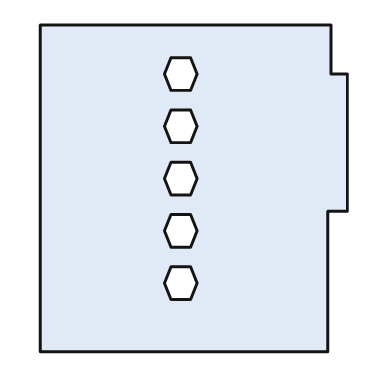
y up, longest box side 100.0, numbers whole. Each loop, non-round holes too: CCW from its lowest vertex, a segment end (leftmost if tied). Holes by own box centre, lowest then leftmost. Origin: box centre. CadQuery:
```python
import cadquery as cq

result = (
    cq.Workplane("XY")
    .moveTo(-47.0, -50.0)
    .lineTo(41.0, -50.0)
    .lineTo(41.0, -7.0)
    .lineTo(47.0, -7.0)
    .lineTo(47.0, 35.0)
    .lineTo(42.0, 35.0)
    .lineTo(42.0, 50.0)
    .lineTo(-47.0, 50.0)
    .close()
    .moveTo(-7.0, -34.0)
    .lineTo(-1.0, -34.0)
    .lineTo(1.0, -29.0)
    .lineTo(-1.0, -24.0)
    .lineTo(-7.0, -24.0)
    .lineTo(-9.0, -29.0)
    .close()
    .moveTo(-7.0, -18.0)
    .lineTo(-1.0, -18.0)
    .lineTo(1.0, -13.0)
    .lineTo(-1.0, -8.0)
    .lineTo(-7.0, -8.0)
    .lineTo(-9.0, -13.0)
    .close()
    .moveTo(-7.0, -2.0)
    .lineTo(-1.0, -2.0)
    .lineTo(1.0, 3.0)
    .lineTo(-1.0, 8.0)
    .lineTo(-7.0, 8.0)
    .lineTo(-9.0, 3.0)
    .close()
    .moveTo(-7.0, 14.0)
    .lineTo(-1.0, 14.0)
    .lineTo(1.0, 19.0)
    .lineTo(-1.0, 24.0)
    .lineTo(-7.0, 24.0)
    .lineTo(-9.0, 19.0)
    .close()
    .moveTo(-7.0, 30.0)
    .lineTo(-1.0, 30.0)
    .lineTo(1.0, 35.0)
    .lineTo(-1.0, 40.0)
    .lineTo(-7.0, 40.0)
    .lineTo(-9.0, 35.0)
    .close()
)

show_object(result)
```